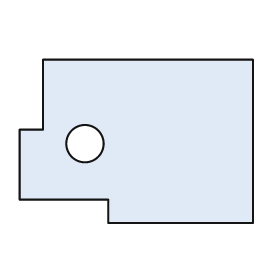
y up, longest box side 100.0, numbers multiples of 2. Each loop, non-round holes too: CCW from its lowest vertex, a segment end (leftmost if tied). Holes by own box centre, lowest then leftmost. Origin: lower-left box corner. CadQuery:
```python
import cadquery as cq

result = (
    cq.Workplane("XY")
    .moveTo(38.0, 0.0)
    .lineTo(100.0, 0.0)
    .lineTo(100.0, 70.0)
    .lineTo(10.0, 70.0)
    .lineTo(10.0, 40.0)
    .lineTo(0.0, 40.0)
    .lineTo(0.0, 10.0)
    .lineTo(38.0, 10.0)
    .close()
    .moveTo(28.0, 34.0)
    .circle(8.0)
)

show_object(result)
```